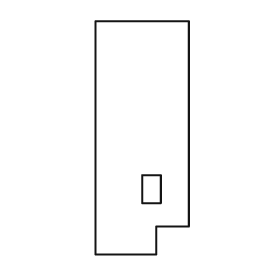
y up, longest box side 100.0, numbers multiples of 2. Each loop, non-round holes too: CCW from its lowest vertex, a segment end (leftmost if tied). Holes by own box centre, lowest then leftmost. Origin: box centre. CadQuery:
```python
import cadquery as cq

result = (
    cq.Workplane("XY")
    .moveTo(-20.0, -50.0)
    .lineTo(6.0, -50.0)
    .lineTo(6.0, -38.0)
    .lineTo(20.0, -38.0)
    .lineTo(20.0, 50.0)
    .lineTo(-20.0, 50.0)
    .close()
    .moveTo(0.0, -28.0)
    .lineTo(8.0, -28.0)
    .lineTo(8.0, -16.0)
    .lineTo(0.0, -16.0)
    .close()
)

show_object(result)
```